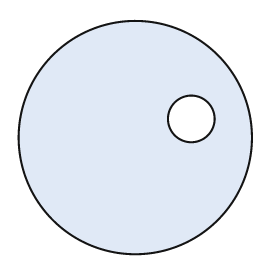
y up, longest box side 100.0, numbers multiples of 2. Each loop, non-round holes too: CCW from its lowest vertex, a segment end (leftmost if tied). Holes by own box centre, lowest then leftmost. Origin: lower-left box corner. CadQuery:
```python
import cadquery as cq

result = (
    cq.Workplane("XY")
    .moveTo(50.0, 50.0)
    .circle(50.0)
    .moveTo(74.0, 58.0)
    .circle(10.0)
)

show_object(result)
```